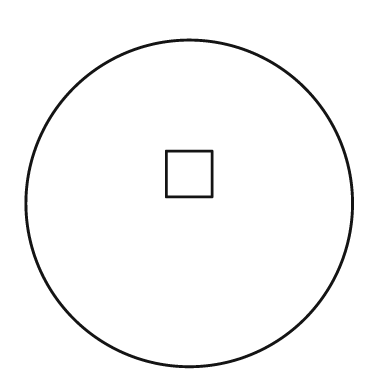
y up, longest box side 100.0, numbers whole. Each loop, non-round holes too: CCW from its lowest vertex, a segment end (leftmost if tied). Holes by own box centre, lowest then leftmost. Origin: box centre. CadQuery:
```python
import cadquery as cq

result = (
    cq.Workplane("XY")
    .moveTo(0.0, 0.0)
    .circle(50.0)
    .moveTo(-7.0, 2.0)
    .lineTo(7.0, 2.0)
    .lineTo(7.0, 16.0)
    .lineTo(-7.0, 16.0)
    .close()
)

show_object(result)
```